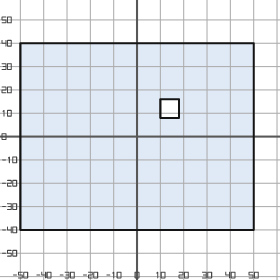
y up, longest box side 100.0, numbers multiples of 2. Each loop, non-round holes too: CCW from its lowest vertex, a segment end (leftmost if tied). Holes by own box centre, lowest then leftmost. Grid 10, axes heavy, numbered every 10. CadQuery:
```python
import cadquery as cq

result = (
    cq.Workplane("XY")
    .moveTo(-50.0, -40.0)
    .lineTo(50.0, -40.0)
    .lineTo(50.0, 40.0)
    .lineTo(-50.0, 40.0)
    .close()
    .moveTo(10.0, 8.0)
    .lineTo(18.0, 8.0)
    .lineTo(18.0, 16.0)
    .lineTo(10.0, 16.0)
    .close()
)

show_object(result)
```